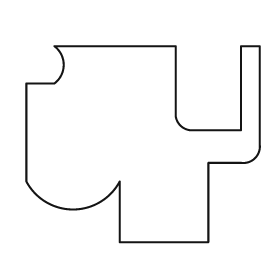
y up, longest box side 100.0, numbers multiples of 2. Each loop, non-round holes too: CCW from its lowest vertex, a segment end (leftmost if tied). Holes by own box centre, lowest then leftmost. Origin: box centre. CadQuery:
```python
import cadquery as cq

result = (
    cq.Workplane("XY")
    .moveTo(-10.0, -42.0)
    .lineTo(28.0, -42.0)
    .lineTo(28.0, -8.0)
    .lineTo(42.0, -8.0)
    .threePointArc((48.0, -6.0), (50.0, 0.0))
    .lineTo(50.0, 42.0)
    .lineTo(42.0, 42.0)
    .lineTo(42.0, 6.0)
    .lineTo(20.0, 6.0)
    .threePointArc((16.0, 8.0), (14.0, 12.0))
    .lineTo(14.0, 42.0)
    .lineTo(-38.0, 42.0)
    .threePointArc((-34.0, 34.0), (-38.0, 26.0))
    .lineTo(-50.0, 26.0)
    .lineTo(-50.0, -16.0)
    .threePointArc((-30.0, -28.0), (-10.0, -16.0))
    .close()
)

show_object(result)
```